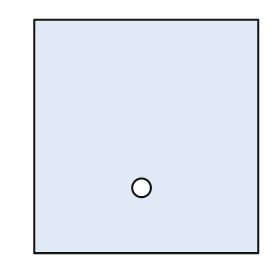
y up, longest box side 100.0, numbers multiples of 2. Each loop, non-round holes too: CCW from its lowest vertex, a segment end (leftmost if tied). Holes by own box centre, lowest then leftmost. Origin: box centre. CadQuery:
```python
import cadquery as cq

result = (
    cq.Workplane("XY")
    .moveTo(-48.0, -50.0)
    .lineTo(48.0, -50.0)
    .lineTo(48.0, 50.0)
    .lineTo(-48.0, 50.0)
    .close()
    .moveTo(-2.0, -22.0)
    .circle(4.0)
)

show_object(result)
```